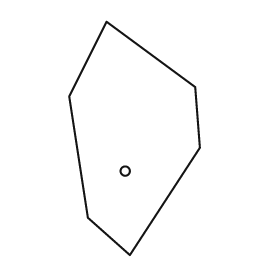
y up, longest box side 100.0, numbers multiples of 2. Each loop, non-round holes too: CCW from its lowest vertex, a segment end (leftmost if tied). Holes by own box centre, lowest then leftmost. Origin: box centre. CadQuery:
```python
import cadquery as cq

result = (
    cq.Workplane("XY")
    .moveTo(-2.0, -50.0)
    .lineTo(28.0, -4.0)
    .lineTo(26.0, 22.0)
    .lineTo(-12.0, 50.0)
    .lineTo(-28.0, 18.0)
    .lineTo(-20.0, -34.0)
    .close()
    .moveTo(-4.0, -14.0)
    .circle(2.0)
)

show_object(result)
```